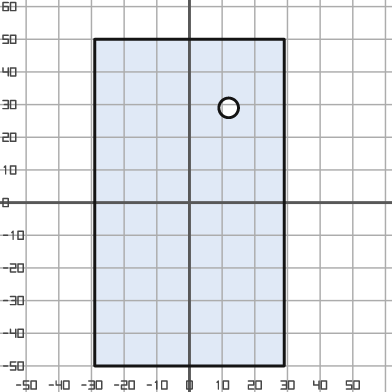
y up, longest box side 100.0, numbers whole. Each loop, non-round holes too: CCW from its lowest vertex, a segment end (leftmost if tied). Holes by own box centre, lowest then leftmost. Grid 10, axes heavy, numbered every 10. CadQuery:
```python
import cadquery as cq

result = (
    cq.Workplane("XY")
    .moveTo(-29.0, -50.0)
    .lineTo(29.0, -50.0)
    .lineTo(29.0, 50.0)
    .lineTo(-29.0, 50.0)
    .close()
    .moveTo(12.0, 29.0)
    .circle(3.0)
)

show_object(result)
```